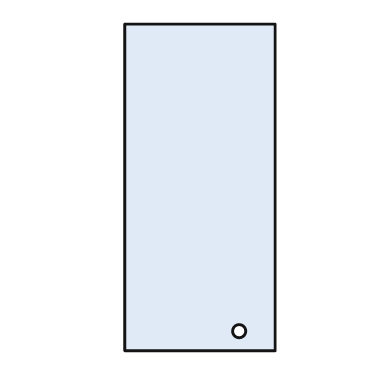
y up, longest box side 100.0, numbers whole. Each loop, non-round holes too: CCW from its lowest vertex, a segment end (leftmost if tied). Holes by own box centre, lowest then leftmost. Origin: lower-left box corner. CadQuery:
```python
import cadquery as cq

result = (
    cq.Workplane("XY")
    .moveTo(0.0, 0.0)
    .lineTo(46.0, 0.0)
    .lineTo(46.0, 100.0)
    .lineTo(0.0, 100.0)
    .close()
    .moveTo(35.0, 6.0)
    .circle(2.0)
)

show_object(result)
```